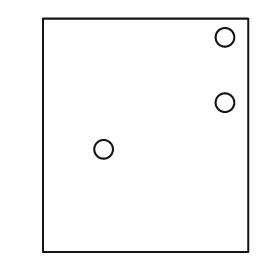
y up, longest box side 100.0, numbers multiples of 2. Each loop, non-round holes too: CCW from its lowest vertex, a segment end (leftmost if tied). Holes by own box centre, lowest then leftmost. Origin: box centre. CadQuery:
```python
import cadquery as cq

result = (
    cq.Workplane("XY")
    .moveTo(-44.0, -50.0)
    .lineTo(44.0, -50.0)
    .lineTo(44.0, 50.0)
    .lineTo(-44.0, 50.0)
    .close()
    .moveTo(-18.0, -6.0)
    .circle(4.0)
    .moveTo(34.0, 14.0)
    .circle(4.0)
    .moveTo(34.0, 42.0)
    .circle(4.0)
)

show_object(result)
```